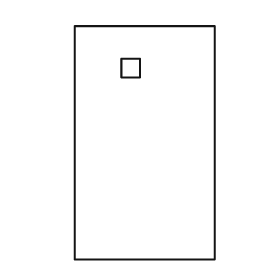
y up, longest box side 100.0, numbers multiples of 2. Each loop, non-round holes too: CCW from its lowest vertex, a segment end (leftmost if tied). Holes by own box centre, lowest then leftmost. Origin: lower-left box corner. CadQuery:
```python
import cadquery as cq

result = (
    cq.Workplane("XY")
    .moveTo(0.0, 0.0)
    .lineTo(60.0, 0.0)
    .lineTo(60.0, 100.0)
    .lineTo(0.0, 100.0)
    .close()
    .moveTo(20.0, 78.0)
    .lineTo(28.0, 78.0)
    .lineTo(28.0, 86.0)
    .lineTo(20.0, 86.0)
    .close()
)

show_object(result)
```